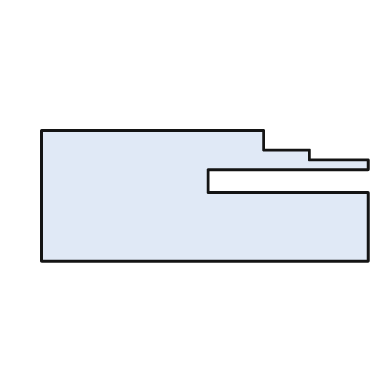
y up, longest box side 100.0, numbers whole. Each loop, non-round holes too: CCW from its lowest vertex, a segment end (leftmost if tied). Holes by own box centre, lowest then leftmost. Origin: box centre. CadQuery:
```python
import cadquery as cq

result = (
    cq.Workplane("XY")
    .moveTo(-50.0, -20.0)
    .lineTo(50.0, -20.0)
    .lineTo(50.0, 1.0)
    .lineTo(1.0, 1.0)
    .lineTo(1.0, 8.0)
    .lineTo(50.0, 8.0)
    .lineTo(50.0, 11.0)
    .lineTo(32.0, 11.0)
    .lineTo(32.0, 14.0)
    .lineTo(18.0, 14.0)
    .lineTo(18.0, 20.0)
    .lineTo(-50.0, 20.0)
    .close()
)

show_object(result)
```